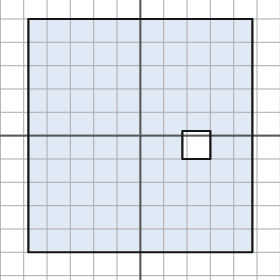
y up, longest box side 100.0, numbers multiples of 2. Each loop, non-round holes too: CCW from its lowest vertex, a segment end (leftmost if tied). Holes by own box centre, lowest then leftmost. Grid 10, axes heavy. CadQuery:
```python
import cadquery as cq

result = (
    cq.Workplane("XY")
    .moveTo(-48.0, -50.0)
    .lineTo(48.0, -50.0)
    .lineTo(48.0, 50.0)
    .lineTo(-48.0, 50.0)
    .close()
    .moveTo(18.0, -10.0)
    .lineTo(30.0, -10.0)
    .lineTo(30.0, 2.0)
    .lineTo(18.0, 2.0)
    .close()
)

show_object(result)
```